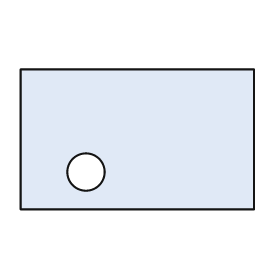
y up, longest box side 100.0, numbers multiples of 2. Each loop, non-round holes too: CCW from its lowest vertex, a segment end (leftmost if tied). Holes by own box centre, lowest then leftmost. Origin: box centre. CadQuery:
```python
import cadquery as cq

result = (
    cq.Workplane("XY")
    .moveTo(-50.0, -30.0)
    .lineTo(50.0, -30.0)
    .lineTo(50.0, 30.0)
    .lineTo(-50.0, 30.0)
    .close()
    .moveTo(-22.0, -14.0)
    .circle(8.0)
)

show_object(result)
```